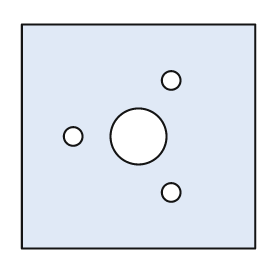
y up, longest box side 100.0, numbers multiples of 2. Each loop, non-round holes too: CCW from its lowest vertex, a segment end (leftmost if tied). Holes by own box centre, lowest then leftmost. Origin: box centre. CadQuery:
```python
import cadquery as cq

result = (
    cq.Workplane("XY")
    .moveTo(-50.0, -48.0)
    .lineTo(50.0, -48.0)
    .lineTo(50.0, 48.0)
    .lineTo(-50.0, 48.0)
    .close()
    .moveTo(14.0, -24.0)
    .circle(4.0)
    .moveTo(-28.0, 0.0)
    .circle(4.0)
    .moveTo(0.0, 0.0)
    .circle(12.0)
    .moveTo(14.0, 24.0)
    .circle(4.0)
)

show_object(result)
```